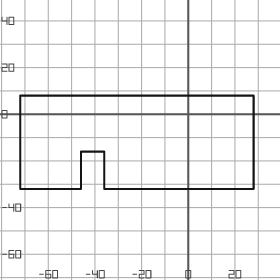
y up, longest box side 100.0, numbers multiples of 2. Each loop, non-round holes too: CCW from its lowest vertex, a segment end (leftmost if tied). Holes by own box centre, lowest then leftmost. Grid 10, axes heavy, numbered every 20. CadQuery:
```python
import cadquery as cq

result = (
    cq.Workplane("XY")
    .moveTo(-72.0, -32.0)
    .lineTo(-46.0, -32.0)
    .lineTo(-46.0, -16.0)
    .lineTo(-36.0, -16.0)
    .lineTo(-36.0, -32.0)
    .lineTo(28.0, -32.0)
    .lineTo(28.0, 8.0)
    .lineTo(-72.0, 8.0)
    .close()
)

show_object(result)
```